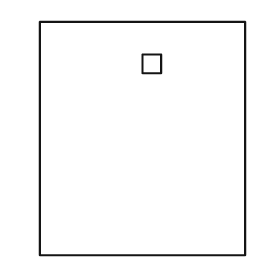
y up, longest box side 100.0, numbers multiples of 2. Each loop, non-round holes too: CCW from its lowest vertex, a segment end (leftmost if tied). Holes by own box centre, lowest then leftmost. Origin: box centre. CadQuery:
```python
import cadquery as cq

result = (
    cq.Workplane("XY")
    .moveTo(-44.0, -50.0)
    .lineTo(44.0, -50.0)
    .lineTo(44.0, 50.0)
    .lineTo(-44.0, 50.0)
    .close()
    .moveTo(0.0, 28.0)
    .lineTo(8.0, 28.0)
    .lineTo(8.0, 36.0)
    .lineTo(0.0, 36.0)
    .close()
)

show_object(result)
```